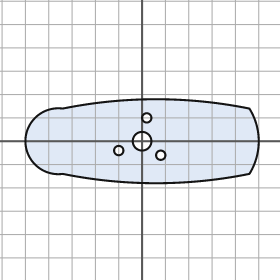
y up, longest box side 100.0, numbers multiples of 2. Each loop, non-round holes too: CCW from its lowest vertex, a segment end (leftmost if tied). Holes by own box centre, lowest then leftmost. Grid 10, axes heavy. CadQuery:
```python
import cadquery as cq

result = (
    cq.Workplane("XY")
    .moveTo(-34.0, -14.0)
    .threePointArc((6.0, -18.0), (46.0, -14.0))
    .threePointArc((50.0, 0.0), (46.0, 14.0))
    .threePointArc((6.0, 18.0), (-34.0, 14.0))
    .threePointArc((-50.0, 0.0), (-34.0, -14.0))
    .close()
    .moveTo(8.0, -6.0)
    .circle(2.0)
    .moveTo(-10.0, -4.0)
    .circle(2.0)
    .moveTo(0.0, 0.0)
    .circle(4.0)
    .moveTo(2.0, 10.0)
    .circle(2.0)
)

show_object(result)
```